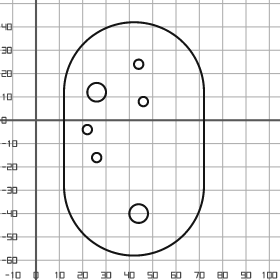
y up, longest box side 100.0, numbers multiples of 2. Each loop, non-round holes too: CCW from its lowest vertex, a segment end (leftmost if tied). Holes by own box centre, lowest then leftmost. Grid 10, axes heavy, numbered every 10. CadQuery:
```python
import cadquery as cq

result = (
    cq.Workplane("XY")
    .moveTo(12.0, -28.0)
    .threePointArc((42.0, -58.0), (72.0, -28.0))
    .lineTo(72.0, 12.0)
    .threePointArc((42.0, 42.0), (12.0, 12.0))
    .close()
    .moveTo(44.0, -40.0)
    .circle(4.0)
    .moveTo(26.0, -16.0)
    .circle(2.0)
    .moveTo(22.0, -4.0)
    .circle(2.0)
    .moveTo(46.0, 8.0)
    .circle(2.0)
    .moveTo(26.0, 12.0)
    .circle(4.0)
    .moveTo(44.0, 24.0)
    .circle(2.0)
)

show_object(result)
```